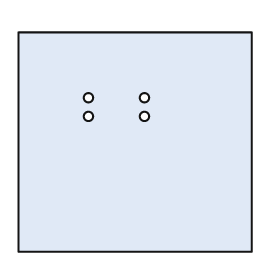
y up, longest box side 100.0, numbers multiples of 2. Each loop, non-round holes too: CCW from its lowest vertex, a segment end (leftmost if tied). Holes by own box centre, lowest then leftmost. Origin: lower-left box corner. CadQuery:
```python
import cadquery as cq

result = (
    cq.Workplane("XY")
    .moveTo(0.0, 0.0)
    .lineTo(100.0, 0.0)
    .lineTo(100.0, 94.0)
    .lineTo(0.0, 94.0)
    .close()
    .moveTo(30.0, 58.0)
    .circle(2.0)
    .moveTo(54.0, 58.0)
    .circle(2.0)
    .moveTo(30.0, 66.0)
    .circle(2.0)
    .moveTo(54.0, 66.0)
    .circle(2.0)
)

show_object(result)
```